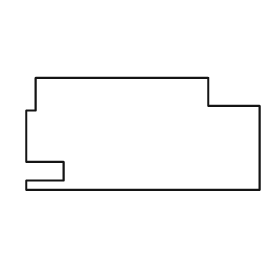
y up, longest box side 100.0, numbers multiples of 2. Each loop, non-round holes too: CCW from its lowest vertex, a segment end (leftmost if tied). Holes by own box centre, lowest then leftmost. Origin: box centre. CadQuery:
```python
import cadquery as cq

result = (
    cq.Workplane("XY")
    .moveTo(-50.0, -24.0)
    .lineTo(50.0, -24.0)
    .lineTo(50.0, 12.0)
    .lineTo(28.0, 12.0)
    .lineTo(28.0, 24.0)
    .lineTo(-46.0, 24.0)
    .lineTo(-46.0, 10.0)
    .lineTo(-50.0, 10.0)
    .lineTo(-50.0, -12.0)
    .lineTo(-34.0, -12.0)
    .lineTo(-34.0, -20.0)
    .lineTo(-50.0, -20.0)
    .close()
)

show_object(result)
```